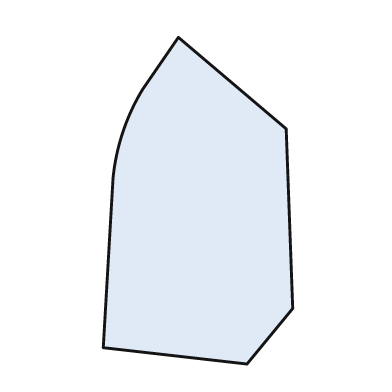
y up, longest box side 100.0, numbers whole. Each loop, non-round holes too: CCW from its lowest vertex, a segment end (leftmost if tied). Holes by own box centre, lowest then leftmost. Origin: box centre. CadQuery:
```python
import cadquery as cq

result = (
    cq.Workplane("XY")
    .moveTo(15.0, -50.0)
    .lineTo(29.0, -33.0)
    .lineTo(27.0, 22.0)
    .lineTo(-6.0, 50.0)
    .lineTo(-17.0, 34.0)
    .threePointArc((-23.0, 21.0), (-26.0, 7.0))
    .lineTo(-29.0, -45.0)
    .close()
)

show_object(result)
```